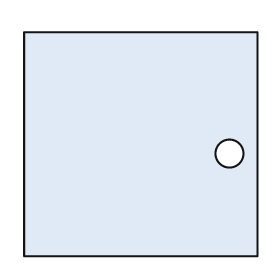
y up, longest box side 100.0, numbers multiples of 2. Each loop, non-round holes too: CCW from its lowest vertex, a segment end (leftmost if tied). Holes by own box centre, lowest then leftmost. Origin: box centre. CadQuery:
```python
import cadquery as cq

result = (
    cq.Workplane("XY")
    .moveTo(-50.0, -48.0)
    .lineTo(50.0, -48.0)
    .lineTo(50.0, 48.0)
    .lineTo(-50.0, 48.0)
    .close()
    .moveTo(38.0, -4.0)
    .circle(6.0)
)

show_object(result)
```